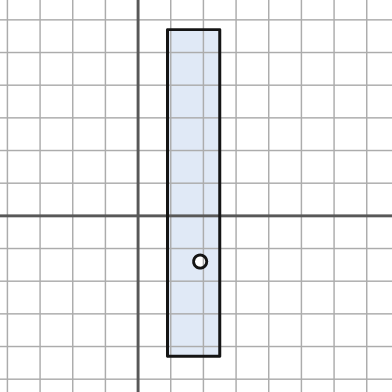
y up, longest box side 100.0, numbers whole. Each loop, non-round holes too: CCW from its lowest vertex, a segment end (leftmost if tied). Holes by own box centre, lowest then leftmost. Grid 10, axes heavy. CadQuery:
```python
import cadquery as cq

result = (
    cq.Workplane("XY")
    .moveTo(9.0, -43.0)
    .lineTo(25.0, -43.0)
    .lineTo(25.0, 57.0)
    .lineTo(9.0, 57.0)
    .close()
    .moveTo(19.0, -14.0)
    .circle(2.0)
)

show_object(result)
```